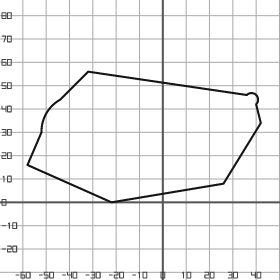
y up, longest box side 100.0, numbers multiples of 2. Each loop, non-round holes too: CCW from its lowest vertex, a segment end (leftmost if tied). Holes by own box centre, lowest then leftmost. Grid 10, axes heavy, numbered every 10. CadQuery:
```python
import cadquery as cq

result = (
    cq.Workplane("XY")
    .moveTo(-22.0, 0.0)
    .lineTo(26.0, 8.0)
    .lineTo(42.0, 34.0)
    .lineTo(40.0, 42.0)
    .threePointArc((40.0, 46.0), (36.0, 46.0))
    .lineTo(-32.0, 56.0)
    .lineTo(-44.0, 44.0)
    .threePointArc((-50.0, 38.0), (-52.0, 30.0))
    .lineTo(-58.0, 16.0)
    .close()
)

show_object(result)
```